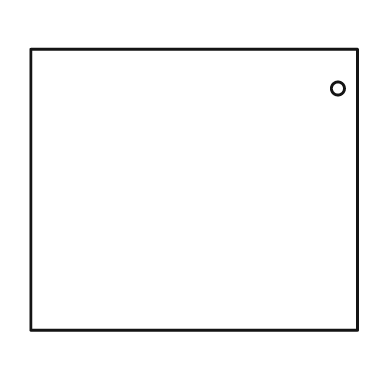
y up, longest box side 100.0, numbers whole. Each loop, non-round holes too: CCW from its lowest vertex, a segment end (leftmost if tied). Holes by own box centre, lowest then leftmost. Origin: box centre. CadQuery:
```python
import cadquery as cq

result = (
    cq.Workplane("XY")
    .moveTo(-50.0, -43.0)
    .lineTo(50.0, -43.0)
    .lineTo(50.0, 43.0)
    .lineTo(-50.0, 43.0)
    .close()
    .moveTo(44.0, 31.0)
    .circle(2.0)
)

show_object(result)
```